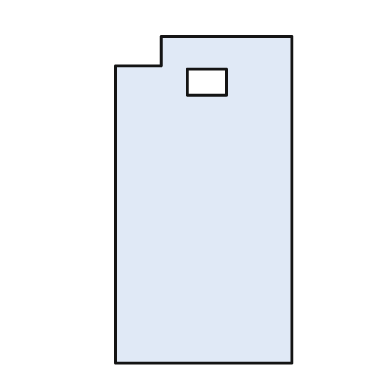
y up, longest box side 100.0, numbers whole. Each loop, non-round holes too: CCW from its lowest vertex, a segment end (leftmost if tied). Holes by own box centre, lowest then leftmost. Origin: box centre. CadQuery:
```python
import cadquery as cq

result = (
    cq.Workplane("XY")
    .moveTo(-27.0, -50.0)
    .lineTo(27.0, -50.0)
    .lineTo(27.0, 50.0)
    .lineTo(-13.0, 50.0)
    .lineTo(-13.0, 41.0)
    .lineTo(-27.0, 41.0)
    .close()
    .moveTo(-5.0, 32.0)
    .lineTo(7.0, 32.0)
    .lineTo(7.0, 40.0)
    .lineTo(-5.0, 40.0)
    .close()
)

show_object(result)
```